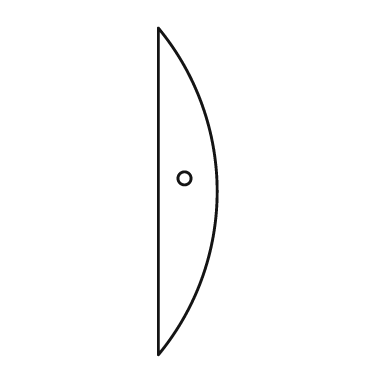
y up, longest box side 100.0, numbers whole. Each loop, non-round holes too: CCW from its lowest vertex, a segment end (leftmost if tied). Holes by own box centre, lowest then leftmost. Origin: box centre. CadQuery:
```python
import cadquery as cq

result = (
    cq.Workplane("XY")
    .moveTo(-9.0, -50.0)
    .threePointArc((9.0, 0.0), (-9.0, 50.0))
    .close()
    .moveTo(-1.0, 4.0)
    .circle(2.0)
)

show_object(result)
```